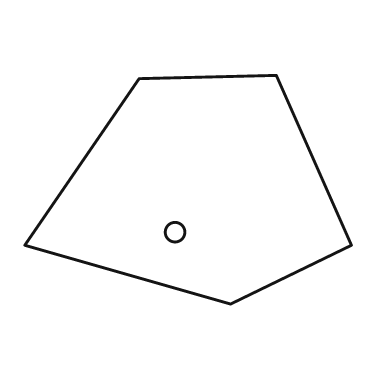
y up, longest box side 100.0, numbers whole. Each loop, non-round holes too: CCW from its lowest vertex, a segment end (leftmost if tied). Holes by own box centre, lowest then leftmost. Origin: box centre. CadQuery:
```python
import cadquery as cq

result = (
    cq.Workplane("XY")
    .moveTo(13.0, -35.0)
    .lineTo(50.0, -17.0)
    .lineTo(27.0, 35.0)
    .lineTo(-15.0, 34.0)
    .lineTo(-50.0, -17.0)
    .close()
    .moveTo(-4.0, -13.0)
    .circle(3.0)
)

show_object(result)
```